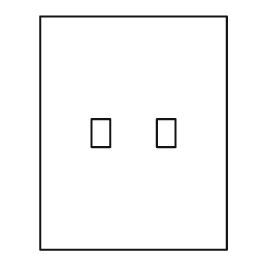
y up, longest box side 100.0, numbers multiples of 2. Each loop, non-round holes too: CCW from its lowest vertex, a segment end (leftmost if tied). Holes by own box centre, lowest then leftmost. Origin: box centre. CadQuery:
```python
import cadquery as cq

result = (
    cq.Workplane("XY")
    .moveTo(-40.0, -50.0)
    .lineTo(40.0, -50.0)
    .lineTo(40.0, 50.0)
    .lineTo(-40.0, 50.0)
    .close()
    .moveTo(-18.0, -6.0)
    .lineTo(-10.0, -6.0)
    .lineTo(-10.0, 6.0)
    .lineTo(-18.0, 6.0)
    .close()
    .moveTo(10.0, -6.0)
    .lineTo(18.0, -6.0)
    .lineTo(18.0, 6.0)
    .lineTo(10.0, 6.0)
    .close()
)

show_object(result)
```